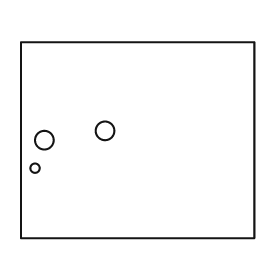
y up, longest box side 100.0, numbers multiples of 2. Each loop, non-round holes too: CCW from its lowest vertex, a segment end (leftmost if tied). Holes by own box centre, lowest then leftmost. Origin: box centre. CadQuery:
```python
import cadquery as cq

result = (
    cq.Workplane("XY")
    .moveTo(-50.0, -42.0)
    .lineTo(50.0, -42.0)
    .lineTo(50.0, 42.0)
    .lineTo(-50.0, 42.0)
    .close()
    .moveTo(-44.0, -12.0)
    .circle(2.0)
    .moveTo(-40.0, 0.0)
    .circle(4.0)
    .moveTo(-14.0, 4.0)
    .circle(4.0)
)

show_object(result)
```